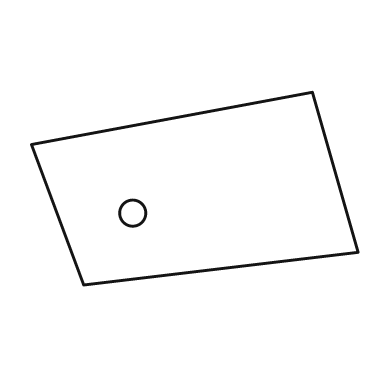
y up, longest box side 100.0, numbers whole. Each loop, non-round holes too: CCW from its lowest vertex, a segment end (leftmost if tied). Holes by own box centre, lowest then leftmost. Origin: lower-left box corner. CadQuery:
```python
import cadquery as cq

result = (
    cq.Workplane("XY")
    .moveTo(16.0, 0.0)
    .lineTo(100.0, 10.0)
    .lineTo(86.0, 59.0)
    .lineTo(0.0, 43.0)
    .close()
    .moveTo(31.0, 22.0)
    .circle(4.0)
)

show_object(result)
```